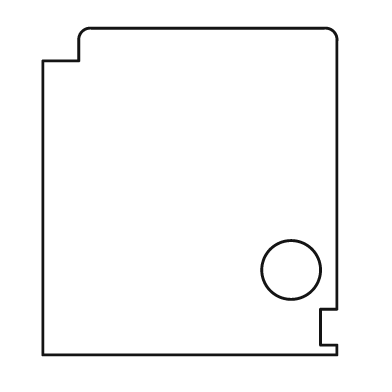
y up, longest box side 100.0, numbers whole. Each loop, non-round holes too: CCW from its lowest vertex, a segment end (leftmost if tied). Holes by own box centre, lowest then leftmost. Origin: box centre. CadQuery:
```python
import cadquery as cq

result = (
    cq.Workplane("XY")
    .moveTo(-45.0, -50.0)
    .lineTo(45.0, -50.0)
    .lineTo(45.0, -47.0)
    .lineTo(40.0, -47.0)
    .lineTo(40.0, -36.0)
    .lineTo(45.0, -36.0)
    .lineTo(45.0, 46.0)
    .threePointArc((44.0, 49.0), (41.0, 50.0))
    .lineTo(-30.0, 50.0)
    .threePointArc((-33.0, 49.0), (-34.0, 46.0))
    .lineTo(-34.0, 40.0)
    .lineTo(-45.0, 40.0)
    .close()
    .moveTo(31.0, -24.0)
    .circle(9.0)
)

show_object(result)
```